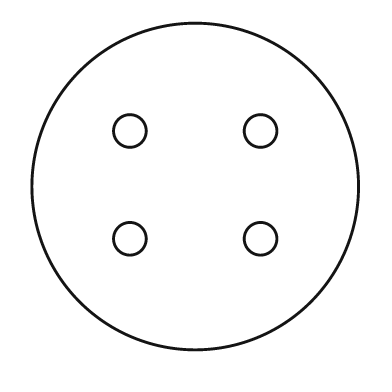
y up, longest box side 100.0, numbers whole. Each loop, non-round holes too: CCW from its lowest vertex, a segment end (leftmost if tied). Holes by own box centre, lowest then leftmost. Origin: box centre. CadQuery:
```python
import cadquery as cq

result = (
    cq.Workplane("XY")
    .moveTo(0.0, 0.0)
    .circle(50.0)
    .moveTo(-20.0, -16.0)
    .circle(5.0)
    .moveTo(20.0, -16.0)
    .circle(5.0)
    .moveTo(-20.0, 17.0)
    .circle(5.0)
    .moveTo(20.0, 17.0)
    .circle(5.0)
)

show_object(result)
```